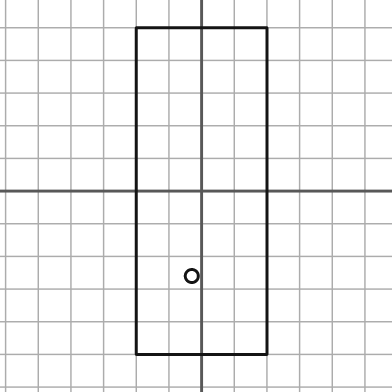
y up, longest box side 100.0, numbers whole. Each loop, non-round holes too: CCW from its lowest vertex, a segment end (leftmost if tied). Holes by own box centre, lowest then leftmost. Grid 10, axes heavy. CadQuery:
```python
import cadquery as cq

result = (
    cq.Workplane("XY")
    .moveTo(-20.0, -50.0)
    .lineTo(20.0, -50.0)
    .lineTo(20.0, 50.0)
    .lineTo(-20.0, 50.0)
    .close()
    .moveTo(-3.0, -26.0)
    .circle(2.0)
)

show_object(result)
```